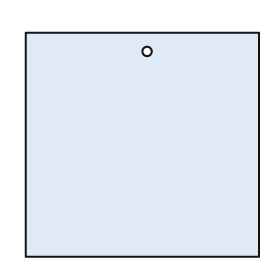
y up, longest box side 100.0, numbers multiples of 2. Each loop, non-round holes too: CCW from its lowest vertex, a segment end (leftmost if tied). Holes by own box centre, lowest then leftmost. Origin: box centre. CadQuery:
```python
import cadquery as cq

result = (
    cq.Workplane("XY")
    .moveTo(-50.0, -48.0)
    .lineTo(50.0, -48.0)
    .lineTo(50.0, 48.0)
    .lineTo(-50.0, 48.0)
    .close()
    .moveTo(2.0, 40.0)
    .circle(2.0)
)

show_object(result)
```